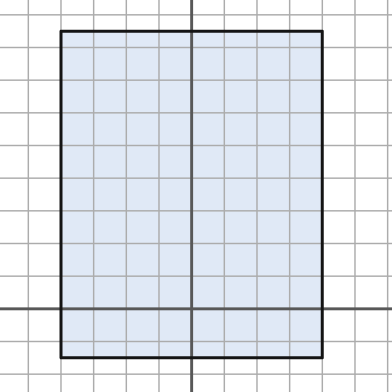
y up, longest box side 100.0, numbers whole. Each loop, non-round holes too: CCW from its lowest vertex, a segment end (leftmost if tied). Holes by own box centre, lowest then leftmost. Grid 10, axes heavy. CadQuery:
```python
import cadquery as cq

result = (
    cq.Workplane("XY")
    .moveTo(-40.0, -15.0)
    .lineTo(40.0, -15.0)
    .lineTo(40.0, 85.0)
    .lineTo(-40.0, 85.0)
    .close()
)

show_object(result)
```